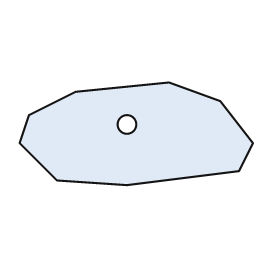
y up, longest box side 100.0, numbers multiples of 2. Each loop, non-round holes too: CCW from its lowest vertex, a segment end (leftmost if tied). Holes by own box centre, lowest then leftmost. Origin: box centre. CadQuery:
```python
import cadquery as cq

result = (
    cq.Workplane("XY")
    .moveTo(-4.0, -22.0)
    .lineTo(44.0, -16.0)
    .lineTo(50.0, -4.0)
    .lineTo(36.0, 14.0)
    .lineTo(14.0, 22.0)
    .lineTo(-26.0, 18.0)
    .lineTo(-46.0, 8.0)
    .lineTo(-50.0, -4.0)
    .lineTo(-34.0, -20.0)
    .close()
    .moveTo(-4.0, 4.0)
    .circle(4.0)
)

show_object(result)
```